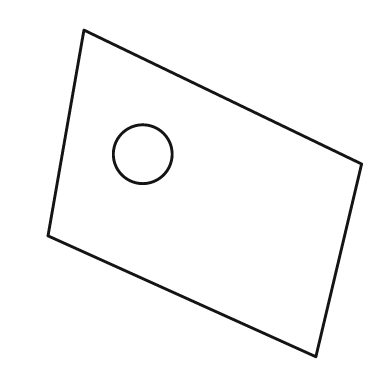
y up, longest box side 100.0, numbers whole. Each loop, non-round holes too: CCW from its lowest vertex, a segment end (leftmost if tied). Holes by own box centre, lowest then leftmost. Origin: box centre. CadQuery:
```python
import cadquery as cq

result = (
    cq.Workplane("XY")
    .moveTo(34.0, -50.0)
    .lineTo(48.0, 9.0)
    .lineTo(-37.0, 50.0)
    .lineTo(-48.0, -13.0)
    .close()
    .moveTo(-19.0, 12.0)
    .circle(9.0)
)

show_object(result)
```